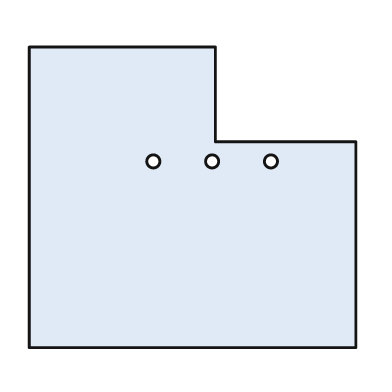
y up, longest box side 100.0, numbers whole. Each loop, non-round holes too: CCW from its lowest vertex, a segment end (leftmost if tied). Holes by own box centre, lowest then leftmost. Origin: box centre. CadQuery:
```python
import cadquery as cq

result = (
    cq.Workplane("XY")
    .moveTo(-50.0, -46.0)
    .lineTo(50.0, -46.0)
    .lineTo(50.0, 17.0)
    .lineTo(7.0, 17.0)
    .lineTo(7.0, 46.0)
    .lineTo(-50.0, 46.0)
    .close()
    .moveTo(-12.0, 11.0)
    .circle(2.0)
    .moveTo(6.0, 11.0)
    .circle(2.0)
    .moveTo(24.0, 11.0)
    .circle(2.0)
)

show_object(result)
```